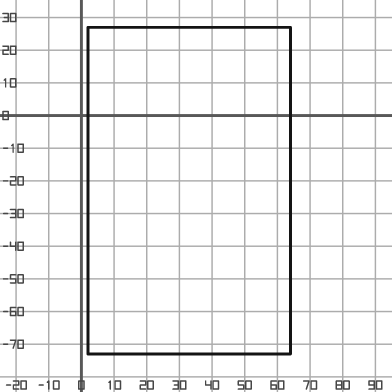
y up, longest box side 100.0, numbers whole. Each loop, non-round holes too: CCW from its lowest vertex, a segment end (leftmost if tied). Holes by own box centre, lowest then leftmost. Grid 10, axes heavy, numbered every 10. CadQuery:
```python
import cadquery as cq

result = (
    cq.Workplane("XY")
    .moveTo(2.0, -73.0)
    .lineTo(64.0, -73.0)
    .lineTo(64.0, 27.0)
    .lineTo(2.0, 27.0)
    .close()
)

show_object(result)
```